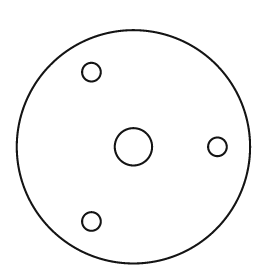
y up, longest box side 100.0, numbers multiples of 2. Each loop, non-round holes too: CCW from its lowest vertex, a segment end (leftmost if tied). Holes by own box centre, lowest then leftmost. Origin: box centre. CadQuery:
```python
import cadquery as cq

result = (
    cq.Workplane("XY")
    .moveTo(0.0, 0.0)
    .circle(50.0)
    .moveTo(-18.0, -32.0)
    .circle(4.0)
    .moveTo(0.0, 0.0)
    .circle(8.0)
    .moveTo(36.0, 0.0)
    .circle(4.0)
    .moveTo(-18.0, 32.0)
    .circle(4.0)
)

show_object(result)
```